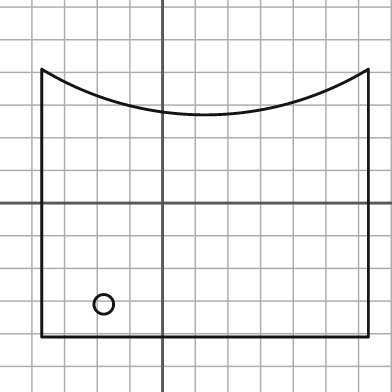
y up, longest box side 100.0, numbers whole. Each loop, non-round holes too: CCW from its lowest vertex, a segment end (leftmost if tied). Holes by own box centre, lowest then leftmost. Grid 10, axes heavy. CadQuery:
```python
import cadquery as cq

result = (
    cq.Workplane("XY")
    .moveTo(-37.0, -41.0)
    .lineTo(63.0, -41.0)
    .lineTo(63.0, 41.0)
    .threePointArc((13.0, 27.0), (-37.0, 41.0))
    .close()
    .moveTo(-18.0, -31.0)
    .circle(3.0)
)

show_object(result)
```